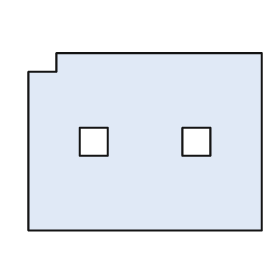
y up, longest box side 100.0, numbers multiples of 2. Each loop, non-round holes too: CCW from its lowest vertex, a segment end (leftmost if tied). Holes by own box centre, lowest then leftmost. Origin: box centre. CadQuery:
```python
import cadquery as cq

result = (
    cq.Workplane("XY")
    .moveTo(-50.0, -38.0)
    .lineTo(50.0, -38.0)
    .lineTo(50.0, 38.0)
    .lineTo(-38.0, 38.0)
    .lineTo(-38.0, 30.0)
    .lineTo(-50.0, 30.0)
    .close()
    .moveTo(-28.0, -6.0)
    .lineTo(-16.0, -6.0)
    .lineTo(-16.0, 6.0)
    .lineTo(-28.0, 6.0)
    .close()
    .moveTo(16.0, -6.0)
    .lineTo(28.0, -6.0)
    .lineTo(28.0, 6.0)
    .lineTo(16.0, 6.0)
    .close()
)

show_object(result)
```